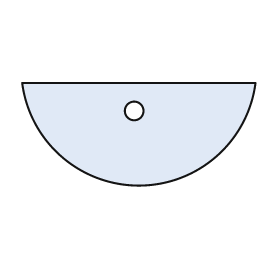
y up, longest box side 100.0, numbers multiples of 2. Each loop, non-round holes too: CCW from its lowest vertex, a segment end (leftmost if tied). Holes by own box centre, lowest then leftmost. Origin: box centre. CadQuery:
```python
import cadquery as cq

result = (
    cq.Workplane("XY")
    .moveTo(-50.0, 22.0)
    .threePointArc((0.0, -22.0), (50.0, 22.0))
    .close()
    .moveTo(-2.0, 10.0)
    .circle(4.0)
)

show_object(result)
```